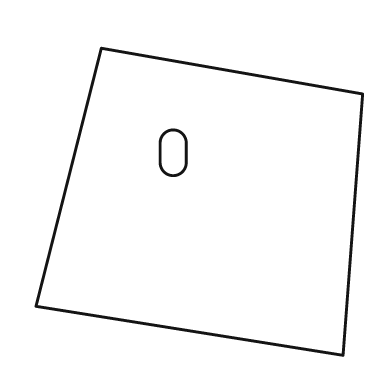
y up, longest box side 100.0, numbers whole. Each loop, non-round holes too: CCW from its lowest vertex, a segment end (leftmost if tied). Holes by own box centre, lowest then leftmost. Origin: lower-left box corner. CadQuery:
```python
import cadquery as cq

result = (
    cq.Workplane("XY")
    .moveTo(94.0, 0.0)
    .lineTo(100.0, 80.0)
    .lineTo(20.0, 94.0)
    .lineTo(0.0, 15.0)
    .close()
    .moveTo(38.0, 59.0)
    .threePointArc((42.0, 55.0), (46.0, 59.0))
    .lineTo(46.0, 65.0)
    .threePointArc((42.0, 69.0), (38.0, 65.0))
    .close()
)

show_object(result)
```